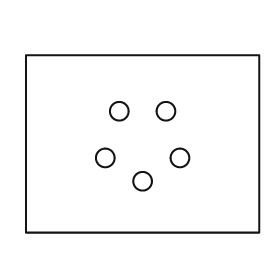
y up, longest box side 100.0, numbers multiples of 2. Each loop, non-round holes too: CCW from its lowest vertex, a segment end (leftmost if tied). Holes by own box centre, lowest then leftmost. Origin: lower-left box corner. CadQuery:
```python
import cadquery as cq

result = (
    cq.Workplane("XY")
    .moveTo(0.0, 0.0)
    .lineTo(100.0, 0.0)
    .lineTo(100.0, 76.0)
    .lineTo(0.0, 76.0)
    .close()
    .moveTo(50.0, 22.0)
    .circle(4.0)
    .moveTo(34.0, 32.0)
    .circle(4.0)
    .moveTo(66.0, 32.0)
    .circle(4.0)
    .moveTo(40.0, 52.0)
    .circle(4.0)
    .moveTo(60.0, 52.0)
    .circle(4.0)
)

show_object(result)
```